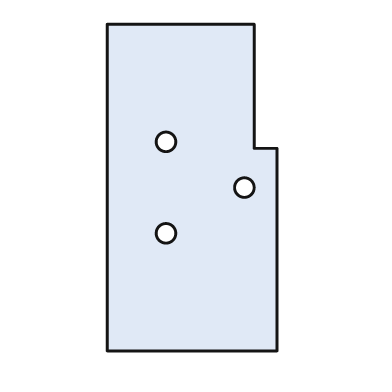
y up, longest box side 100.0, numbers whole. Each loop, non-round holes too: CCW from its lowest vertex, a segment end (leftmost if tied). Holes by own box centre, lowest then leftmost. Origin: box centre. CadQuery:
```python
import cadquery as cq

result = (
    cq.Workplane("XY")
    .moveTo(-26.0, -50.0)
    .lineTo(26.0, -50.0)
    .lineTo(26.0, 12.0)
    .lineTo(19.0, 12.0)
    .lineTo(19.0, 50.0)
    .lineTo(-26.0, 50.0)
    .close()
    .moveTo(-8.0, -14.0)
    .circle(3.0)
    .moveTo(16.0, 0.0)
    .circle(3.0)
    .moveTo(-8.0, 14.0)
    .circle(3.0)
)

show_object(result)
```